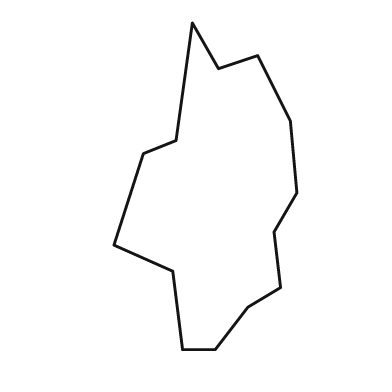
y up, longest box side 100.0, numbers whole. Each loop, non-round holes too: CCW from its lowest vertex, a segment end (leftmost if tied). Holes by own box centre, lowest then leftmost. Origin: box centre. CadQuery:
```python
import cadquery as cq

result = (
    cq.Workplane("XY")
    .moveTo(-7.0, -50.0)
    .lineTo(3.0, -50.0)
    .lineTo(13.0, -37.0)
    .lineTo(23.0, -31.0)
    .lineTo(21.0, -14.0)
    .lineTo(28.0, -2.0)
    .lineTo(26.0, 20.0)
    .lineTo(16.0, 40.0)
    .lineTo(4.0, 36.0)
    .lineTo(-4.0, 50.0)
    .lineTo(-9.0, 14.0)
    .lineTo(-19.0, 10.0)
    .lineTo(-28.0, -18.0)
    .lineTo(-10.0, -26.0)
    .close()
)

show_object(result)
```